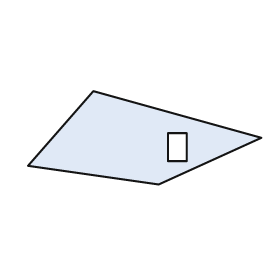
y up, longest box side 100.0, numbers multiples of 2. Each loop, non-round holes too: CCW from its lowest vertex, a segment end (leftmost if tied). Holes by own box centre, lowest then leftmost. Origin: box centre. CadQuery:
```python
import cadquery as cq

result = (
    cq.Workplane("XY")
    .moveTo(6.0, -20.0)
    .lineTo(50.0, 0.0)
    .lineTo(-22.0, 20.0)
    .lineTo(-50.0, -12.0)
    .close()
    .moveTo(10.0, -10.0)
    .lineTo(18.0, -10.0)
    .lineTo(18.0, 2.0)
    .lineTo(10.0, 2.0)
    .close()
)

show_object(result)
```